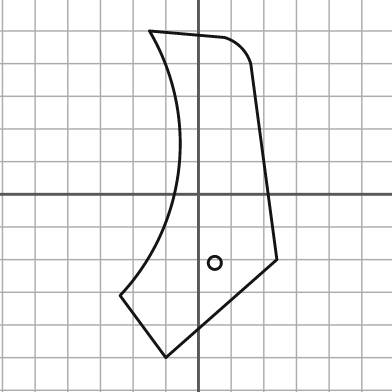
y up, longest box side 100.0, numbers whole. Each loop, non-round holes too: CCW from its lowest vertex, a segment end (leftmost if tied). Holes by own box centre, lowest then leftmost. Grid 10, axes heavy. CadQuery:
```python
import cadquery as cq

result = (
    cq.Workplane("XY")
    .moveTo(-10.0, -50.0)
    .lineTo(24.0, -20.0)
    .lineTo(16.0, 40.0)
    .threePointArc((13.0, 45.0), (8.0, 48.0))
    .lineTo(-15.0, 50.0)
    .threePointArc((-6.0, 8.0), (-24.0, -31.0))
    .close()
    .moveTo(5.0, -21.0)
    .circle(2.0)
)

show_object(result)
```